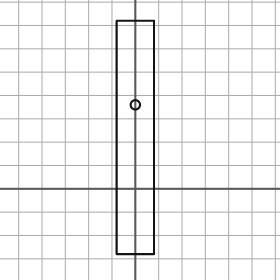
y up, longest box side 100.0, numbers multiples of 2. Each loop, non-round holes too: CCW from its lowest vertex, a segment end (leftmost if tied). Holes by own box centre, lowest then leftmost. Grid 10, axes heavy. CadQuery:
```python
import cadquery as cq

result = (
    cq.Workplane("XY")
    .moveTo(-8.0, -28.0)
    .lineTo(8.0, -28.0)
    .lineTo(8.0, 72.0)
    .lineTo(-8.0, 72.0)
    .close()
    .moveTo(0.0, 36.0)
    .circle(2.0)
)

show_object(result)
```